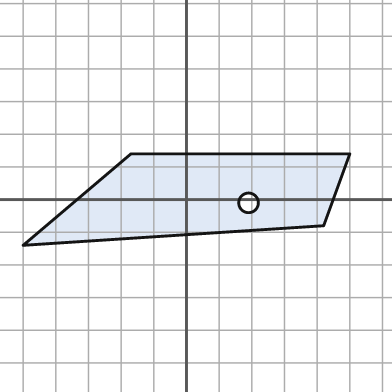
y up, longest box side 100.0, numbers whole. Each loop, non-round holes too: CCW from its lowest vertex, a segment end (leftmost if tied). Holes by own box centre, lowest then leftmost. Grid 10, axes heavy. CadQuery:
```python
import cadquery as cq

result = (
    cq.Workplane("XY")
    .moveTo(-50.0, -14.0)
    .lineTo(42.0, -8.0)
    .lineTo(50.0, 14.0)
    .lineTo(-17.0, 14.0)
    .close()
    .moveTo(19.0, -1.0)
    .circle(3.0)
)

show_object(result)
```